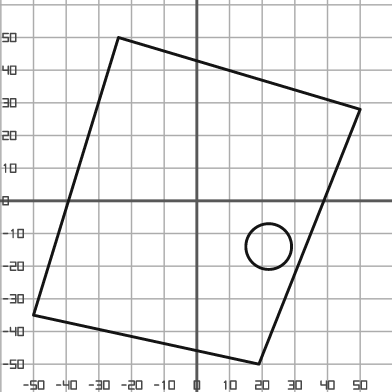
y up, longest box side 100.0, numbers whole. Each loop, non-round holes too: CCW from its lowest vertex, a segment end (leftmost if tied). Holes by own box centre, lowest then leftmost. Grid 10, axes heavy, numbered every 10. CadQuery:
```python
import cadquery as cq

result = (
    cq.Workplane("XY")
    .moveTo(19.0, -50.0)
    .lineTo(50.0, 28.0)
    .lineTo(-24.0, 50.0)
    .lineTo(-50.0, -35.0)
    .close()
    .moveTo(22.0, -14.0)
    .circle(7.0)
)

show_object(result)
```